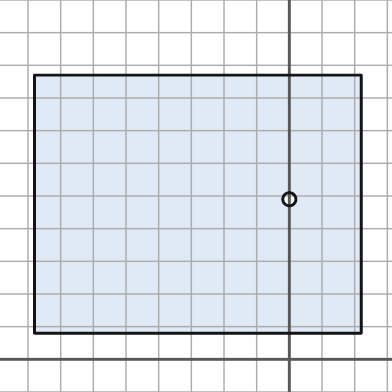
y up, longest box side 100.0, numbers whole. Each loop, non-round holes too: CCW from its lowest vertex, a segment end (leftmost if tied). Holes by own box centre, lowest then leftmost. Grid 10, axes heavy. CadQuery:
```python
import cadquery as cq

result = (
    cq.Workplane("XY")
    .moveTo(-78.0, 8.0)
    .lineTo(22.0, 8.0)
    .lineTo(22.0, 87.0)
    .lineTo(-78.0, 87.0)
    .close()
    .moveTo(0.0, 49.0)
    .circle(2.0)
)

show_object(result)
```